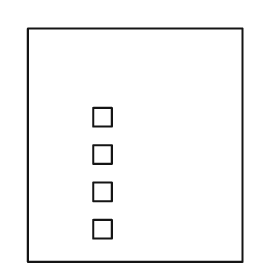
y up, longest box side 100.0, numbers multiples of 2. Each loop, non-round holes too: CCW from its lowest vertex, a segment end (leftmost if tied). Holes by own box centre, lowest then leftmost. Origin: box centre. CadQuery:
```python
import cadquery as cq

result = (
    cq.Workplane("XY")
    .moveTo(-46.0, -50.0)
    .lineTo(46.0, -50.0)
    .lineTo(46.0, 50.0)
    .lineTo(-46.0, 50.0)
    .close()
    .moveTo(-18.0, -40.0)
    .lineTo(-10.0, -40.0)
    .lineTo(-10.0, -32.0)
    .lineTo(-18.0, -32.0)
    .close()
    .moveTo(-18.0, -24.0)
    .lineTo(-10.0, -24.0)
    .lineTo(-10.0, -16.0)
    .lineTo(-18.0, -16.0)
    .close()
    .moveTo(-18.0, -8.0)
    .lineTo(-10.0, -8.0)
    .lineTo(-10.0, 0.0)
    .lineTo(-18.0, 0.0)
    .close()
    .moveTo(-18.0, 8.0)
    .lineTo(-10.0, 8.0)
    .lineTo(-10.0, 16.0)
    .lineTo(-18.0, 16.0)
    .close()
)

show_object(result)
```